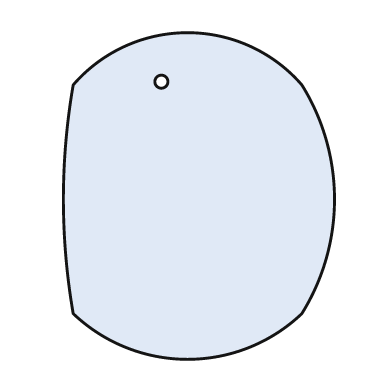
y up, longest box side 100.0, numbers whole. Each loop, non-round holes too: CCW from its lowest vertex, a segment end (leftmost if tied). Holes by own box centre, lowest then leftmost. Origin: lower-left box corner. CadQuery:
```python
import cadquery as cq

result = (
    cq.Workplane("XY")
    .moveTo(3.0, 14.0)
    .threePointArc((38.0, 0.0), (73.0, 14.0))
    .threePointArc((83.0, 49.0), (73.0, 84.0))
    .threePointArc((38.0, 100.0), (3.0, 84.0))
    .threePointArc((0.0, 49.0), (3.0, 14.0))
    .close()
    .moveTo(30.0, 85.0)
    .circle(2.0)
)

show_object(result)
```